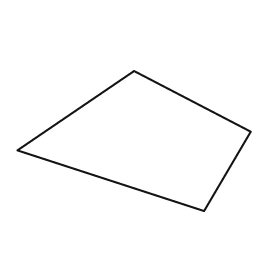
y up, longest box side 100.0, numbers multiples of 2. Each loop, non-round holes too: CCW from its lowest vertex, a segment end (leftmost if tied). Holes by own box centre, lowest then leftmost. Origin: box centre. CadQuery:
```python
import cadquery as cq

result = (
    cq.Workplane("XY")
    .moveTo(30.0, -30.0)
    .lineTo(50.0, 4.0)
    .lineTo(0.0, 30.0)
    .lineTo(-50.0, -4.0)
    .close()
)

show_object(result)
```